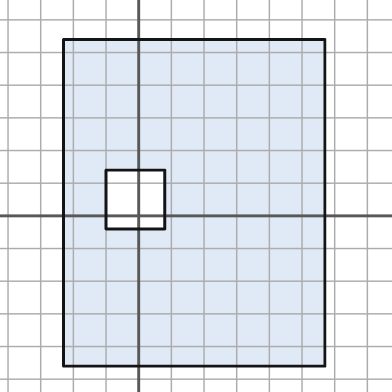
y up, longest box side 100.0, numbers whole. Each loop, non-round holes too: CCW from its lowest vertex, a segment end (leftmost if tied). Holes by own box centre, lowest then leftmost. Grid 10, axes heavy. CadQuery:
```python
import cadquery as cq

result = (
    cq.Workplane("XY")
    .moveTo(-23.0, -46.0)
    .lineTo(57.0, -46.0)
    .lineTo(57.0, 54.0)
    .lineTo(-23.0, 54.0)
    .close()
    .moveTo(-10.0, -4.0)
    .lineTo(8.0, -4.0)
    .lineTo(8.0, 14.0)
    .lineTo(-10.0, 14.0)
    .close()
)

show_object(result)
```